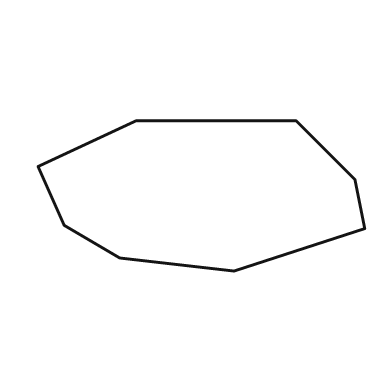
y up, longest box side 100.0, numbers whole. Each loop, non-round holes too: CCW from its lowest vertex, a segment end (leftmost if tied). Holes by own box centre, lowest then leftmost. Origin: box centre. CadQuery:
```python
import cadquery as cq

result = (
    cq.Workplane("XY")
    .moveTo(10.0, -23.0)
    .lineTo(50.0, -10.0)
    .lineTo(47.0, 5.0)
    .lineTo(29.0, 23.0)
    .lineTo(-20.0, 23.0)
    .lineTo(-50.0, 9.0)
    .lineTo(-42.0, -9.0)
    .lineTo(-25.0, -19.0)
    .close()
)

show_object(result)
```